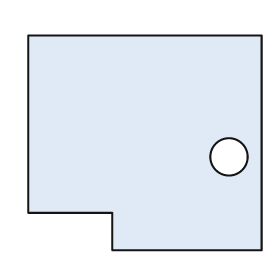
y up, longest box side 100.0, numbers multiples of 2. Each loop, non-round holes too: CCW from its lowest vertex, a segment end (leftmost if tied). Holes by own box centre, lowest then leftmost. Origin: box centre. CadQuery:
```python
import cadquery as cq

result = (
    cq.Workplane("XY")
    .moveTo(-14.0, -46.0)
    .lineTo(50.0, -46.0)
    .lineTo(50.0, 46.0)
    .lineTo(-50.0, 46.0)
    .lineTo(-50.0, -30.0)
    .lineTo(-14.0, -30.0)
    .close()
    .moveTo(36.0, -6.0)
    .circle(8.0)
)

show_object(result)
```